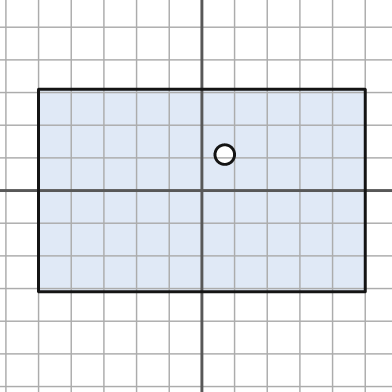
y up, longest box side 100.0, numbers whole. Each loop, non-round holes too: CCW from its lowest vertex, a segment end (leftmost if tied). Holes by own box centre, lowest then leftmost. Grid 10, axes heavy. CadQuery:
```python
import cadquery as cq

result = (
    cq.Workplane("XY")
    .moveTo(-50.0, -31.0)
    .lineTo(50.0, -31.0)
    .lineTo(50.0, 31.0)
    .lineTo(-50.0, 31.0)
    .close()
    .moveTo(7.0, 11.0)
    .circle(3.0)
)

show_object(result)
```